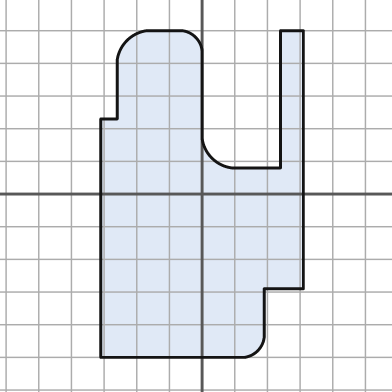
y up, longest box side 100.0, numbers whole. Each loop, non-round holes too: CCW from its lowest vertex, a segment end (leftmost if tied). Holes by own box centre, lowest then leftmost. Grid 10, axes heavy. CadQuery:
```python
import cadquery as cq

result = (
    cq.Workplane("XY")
    .moveTo(-31.0, -50.0)
    .lineTo(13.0, -50.0)
    .threePointArc((17.0, -48.0), (19.0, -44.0))
    .lineTo(19.0, -29.0)
    .lineTo(31.0, -29.0)
    .lineTo(31.0, 50.0)
    .lineTo(24.0, 50.0)
    .lineTo(24.0, 8.0)
    .lineTo(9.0, 8.0)
    .threePointArc((3.0, 11.0), (0.0, 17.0))
    .lineTo(0.0, 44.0)
    .threePointArc((-2.0, 48.0), (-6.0, 50.0))
    .lineTo(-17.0, 50.0)
    .threePointArc((-23.0, 47.0), (-26.0, 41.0))
    .lineTo(-26.0, 23.0)
    .lineTo(-31.0, 23.0)
    .close()
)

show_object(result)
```